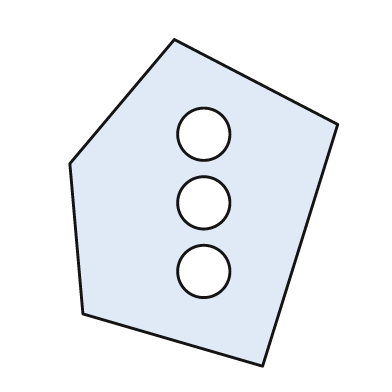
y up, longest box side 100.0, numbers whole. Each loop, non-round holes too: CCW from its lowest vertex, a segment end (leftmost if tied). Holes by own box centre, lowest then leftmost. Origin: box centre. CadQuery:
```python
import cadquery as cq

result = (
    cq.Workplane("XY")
    .moveTo(18.0, -50.0)
    .lineTo(41.0, 24.0)
    .lineTo(-9.0, 50.0)
    .lineTo(-41.0, 12.0)
    .lineTo(-37.0, -34.0)
    .close()
    .moveTo(0.0, -21.0)
    .circle(8.0)
    .moveTo(0.0, 0.0)
    .circle(8.0)
    .moveTo(0.0, 21.0)
    .circle(8.0)
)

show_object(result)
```